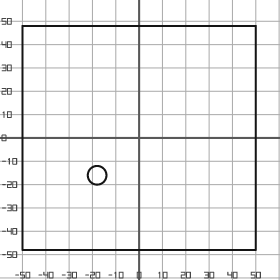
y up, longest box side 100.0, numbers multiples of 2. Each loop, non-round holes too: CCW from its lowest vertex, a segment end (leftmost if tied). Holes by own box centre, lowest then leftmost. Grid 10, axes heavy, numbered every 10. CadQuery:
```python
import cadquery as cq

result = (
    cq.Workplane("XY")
    .moveTo(-50.0, -48.0)
    .lineTo(50.0, -48.0)
    .lineTo(50.0, 48.0)
    .lineTo(-50.0, 48.0)
    .close()
    .moveTo(-18.0, -16.0)
    .circle(4.0)
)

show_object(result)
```